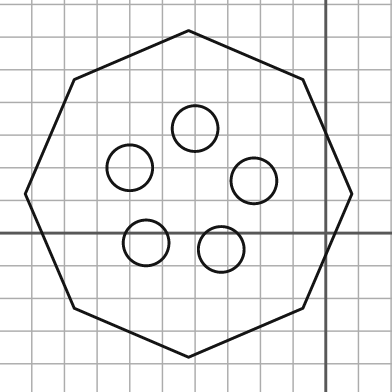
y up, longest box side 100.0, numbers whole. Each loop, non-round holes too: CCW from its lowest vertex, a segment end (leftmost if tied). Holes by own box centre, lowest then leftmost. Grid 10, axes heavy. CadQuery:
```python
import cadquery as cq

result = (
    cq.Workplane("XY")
    .moveTo(-42.0, -38.0)
    .lineTo(-7.0, -23.0)
    .lineTo(8.0, 12.0)
    .lineTo(-7.0, 47.0)
    .lineTo(-42.0, 62.0)
    .lineTo(-77.0, 47.0)
    .lineTo(-92.0, 12.0)
    .lineTo(-77.0, -23.0)
    .close()
    .moveTo(-32.0, -5.0)
    .circle(7.0)
    .moveTo(-55.0, -3.0)
    .circle(7.0)
    .moveTo(-22.0, 16.0)
    .circle(7.0)
    .moveTo(-60.0, 20.0)
    .circle(7.0)
    .moveTo(-40.0, 32.0)
    .circle(7.0)
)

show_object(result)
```